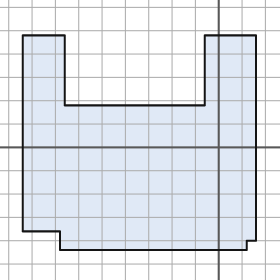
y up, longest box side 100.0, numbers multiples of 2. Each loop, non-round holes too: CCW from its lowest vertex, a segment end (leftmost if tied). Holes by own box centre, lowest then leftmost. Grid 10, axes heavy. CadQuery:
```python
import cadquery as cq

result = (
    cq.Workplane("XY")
    .moveTo(-68.0, -44.0)
    .lineTo(12.0, -44.0)
    .lineTo(12.0, -40.0)
    .lineTo(16.0, -40.0)
    .lineTo(16.0, 48.0)
    .lineTo(-6.0, 48.0)
    .lineTo(-6.0, 18.0)
    .lineTo(-66.0, 18.0)
    .lineTo(-66.0, 48.0)
    .lineTo(-84.0, 48.0)
    .lineTo(-84.0, -36.0)
    .lineTo(-68.0, -36.0)
    .close()
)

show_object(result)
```